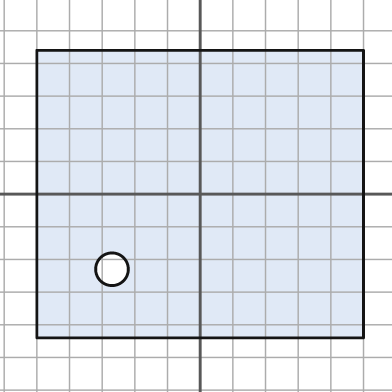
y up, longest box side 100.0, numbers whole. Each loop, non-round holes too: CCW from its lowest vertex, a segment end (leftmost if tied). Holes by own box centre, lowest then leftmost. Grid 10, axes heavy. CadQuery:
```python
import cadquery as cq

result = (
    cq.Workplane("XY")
    .moveTo(-50.0, -44.0)
    .lineTo(50.0, -44.0)
    .lineTo(50.0, 44.0)
    .lineTo(-50.0, 44.0)
    .close()
    .moveTo(-27.0, -23.0)
    .circle(5.0)
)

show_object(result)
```